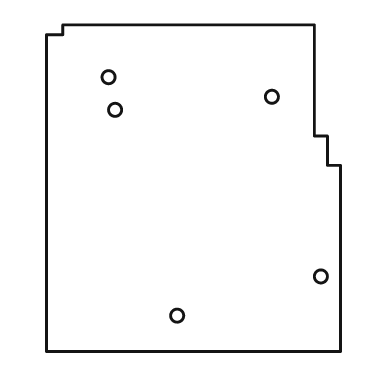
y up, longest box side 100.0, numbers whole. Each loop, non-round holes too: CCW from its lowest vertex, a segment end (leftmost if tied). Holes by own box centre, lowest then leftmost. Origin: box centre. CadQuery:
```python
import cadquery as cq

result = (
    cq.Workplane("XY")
    .moveTo(-45.0, -50.0)
    .lineTo(45.0, -50.0)
    .lineTo(45.0, 7.0)
    .lineTo(41.0, 7.0)
    .lineTo(41.0, 16.0)
    .lineTo(37.0, 16.0)
    .lineTo(37.0, 50.0)
    .lineTo(-40.0, 50.0)
    .lineTo(-40.0, 47.0)
    .lineTo(-45.0, 47.0)
    .close()
    .moveTo(-5.0, -39.0)
    .circle(2.0)
    .moveTo(39.0, -27.0)
    .circle(2.0)
    .moveTo(-24.0, 24.0)
    .circle(2.0)
    .moveTo(24.0, 28.0)
    .circle(2.0)
    .moveTo(-26.0, 34.0)
    .circle(2.0)
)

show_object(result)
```